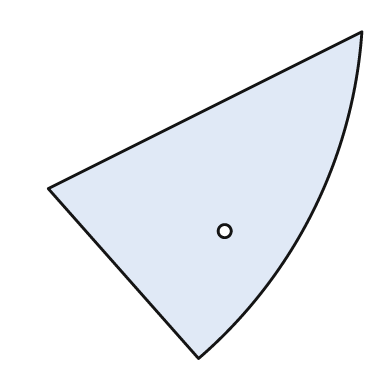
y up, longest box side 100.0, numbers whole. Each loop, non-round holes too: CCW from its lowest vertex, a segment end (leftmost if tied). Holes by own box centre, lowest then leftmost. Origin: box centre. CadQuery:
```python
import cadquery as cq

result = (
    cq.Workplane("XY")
    .moveTo(-2.0, -50.0)
    .threePointArc((33.0, -5.0), (48.0, 50.0))
    .lineTo(-48.0, 2.0)
    .close()
    .moveTo(6.0, -11.0)
    .circle(2.0)
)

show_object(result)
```